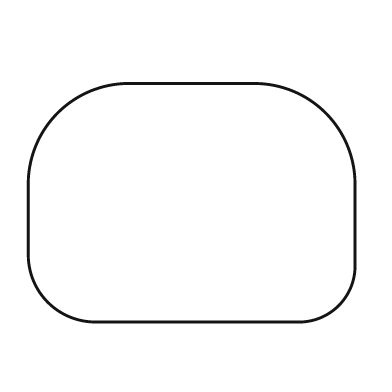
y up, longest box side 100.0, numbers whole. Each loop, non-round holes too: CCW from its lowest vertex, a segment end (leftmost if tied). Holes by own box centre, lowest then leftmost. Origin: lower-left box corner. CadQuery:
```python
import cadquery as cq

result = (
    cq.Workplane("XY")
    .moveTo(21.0, 0.0)
    .lineTo(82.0, 0.0)
    .threePointArc((95.0, 5.0), (100.0, 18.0))
    .lineTo(100.0, 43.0)
    .threePointArc((91.0, 64.0), (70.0, 73.0))
    .lineTo(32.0, 73.0)
    .threePointArc((9.0, 64.0), (0.0, 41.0))
    .lineTo(0.0, 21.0)
    .threePointArc((6.0, 6.0), (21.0, 0.0))
    .close()
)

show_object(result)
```